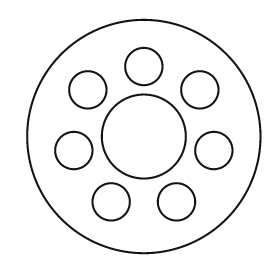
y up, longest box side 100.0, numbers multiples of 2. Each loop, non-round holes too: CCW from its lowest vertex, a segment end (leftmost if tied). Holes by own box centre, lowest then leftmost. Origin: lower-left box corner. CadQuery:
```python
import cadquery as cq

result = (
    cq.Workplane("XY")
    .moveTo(50.0, 50.0)
    .circle(50.0)
    .moveTo(36.0, 22.0)
    .circle(8.0)
    .moveTo(64.0, 22.0)
    .circle(8.0)
    .moveTo(20.0, 44.0)
    .circle(8.0)
    .moveTo(80.0, 44.0)
    .circle(8.0)
    .moveTo(50.0, 50.0)
    .circle(18.0)
    .moveTo(26.0, 70.0)
    .circle(8.0)
    .moveTo(74.0, 70.0)
    .circle(8.0)
    .moveTo(50.0, 80.0)
    .circle(8.0)
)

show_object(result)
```